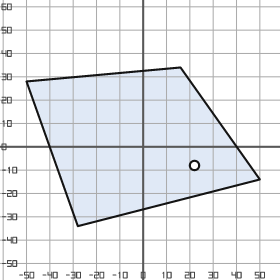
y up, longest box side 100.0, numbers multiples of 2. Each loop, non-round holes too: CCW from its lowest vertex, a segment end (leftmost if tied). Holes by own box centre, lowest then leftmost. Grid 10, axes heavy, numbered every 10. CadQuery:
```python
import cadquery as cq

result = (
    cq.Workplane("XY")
    .moveTo(-28.0, -34.0)
    .lineTo(50.0, -14.0)
    .lineTo(16.0, 34.0)
    .lineTo(-50.0, 28.0)
    .close()
    .moveTo(22.0, -8.0)
    .circle(2.0)
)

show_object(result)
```